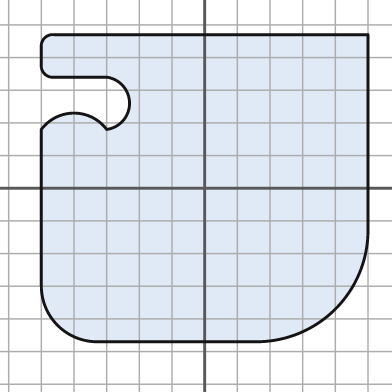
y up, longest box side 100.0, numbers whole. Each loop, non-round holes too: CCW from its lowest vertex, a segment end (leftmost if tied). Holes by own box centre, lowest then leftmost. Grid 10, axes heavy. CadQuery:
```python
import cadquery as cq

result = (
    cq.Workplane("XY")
    .moveTo(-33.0, -47.0)
    .lineTo(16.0, -47.0)
    .threePointArc((40.0, -37.0), (50.0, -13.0))
    .lineTo(50.0, 47.0)
    .lineTo(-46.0, 47.0)
    .threePointArc((-49.0, 46.0), (-50.0, 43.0))
    .lineTo(-50.0, 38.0)
    .threePointArc((-49.0, 35.0), (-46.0, 34.0))
    .lineTo(-30.0, 34.0)
    .threePointArc((-23.0, 26.0), (-30.0, 18.0))
    .threePointArc((-40.0, 23.0), (-50.0, 18.0))
    .lineTo(-50.0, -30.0)
    .threePointArc((-45.0, -42.0), (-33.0, -47.0))
    .close()
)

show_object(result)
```